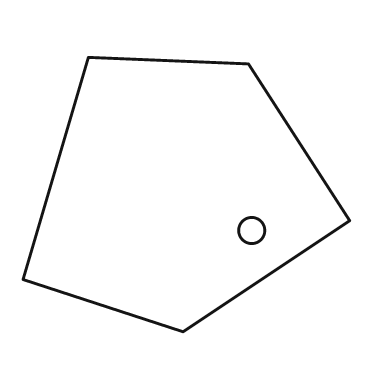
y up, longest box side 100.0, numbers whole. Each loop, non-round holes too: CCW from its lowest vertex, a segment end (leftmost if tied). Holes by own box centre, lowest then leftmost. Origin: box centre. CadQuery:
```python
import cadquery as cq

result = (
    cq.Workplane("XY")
    .moveTo(-1.0, -42.0)
    .lineTo(50.0, -8.0)
    .lineTo(19.0, 40.0)
    .lineTo(-30.0, 42.0)
    .lineTo(-50.0, -26.0)
    .close()
    .moveTo(20.0, -11.0)
    .circle(4.0)
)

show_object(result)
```